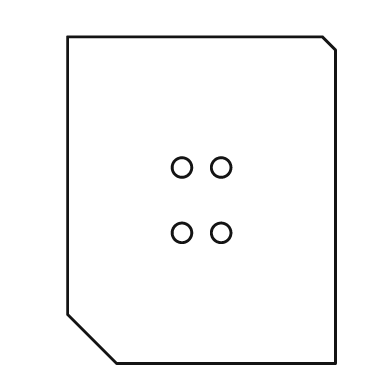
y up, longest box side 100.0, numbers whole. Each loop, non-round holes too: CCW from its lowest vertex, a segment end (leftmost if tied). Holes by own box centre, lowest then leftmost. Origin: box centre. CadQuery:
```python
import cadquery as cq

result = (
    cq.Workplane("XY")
    .moveTo(-26.0, -50.0)
    .lineTo(41.0, -50.0)
    .lineTo(41.0, 46.0)
    .lineTo(37.0, 50.0)
    .lineTo(-41.0, 50.0)
    .lineTo(-41.0, -35.0)
    .close()
    .moveTo(-6.0, -10.0)
    .circle(3.0)
    .moveTo(6.0, -10.0)
    .circle(3.0)
    .moveTo(-6.0, 10.0)
    .circle(3.0)
    .moveTo(6.0, 10.0)
    .circle(3.0)
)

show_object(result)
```